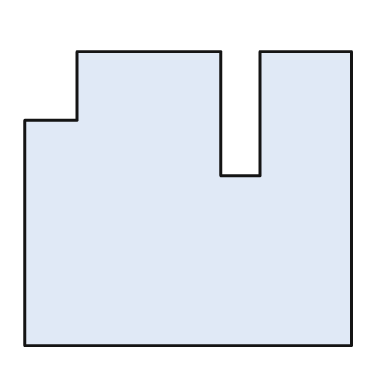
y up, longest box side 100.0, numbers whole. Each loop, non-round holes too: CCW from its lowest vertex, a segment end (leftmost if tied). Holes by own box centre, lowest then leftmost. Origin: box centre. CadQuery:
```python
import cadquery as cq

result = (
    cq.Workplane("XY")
    .moveTo(-50.0, -45.0)
    .lineTo(50.0, -45.0)
    .lineTo(50.0, 45.0)
    .lineTo(22.0, 45.0)
    .lineTo(22.0, 7.0)
    .lineTo(10.0, 7.0)
    .lineTo(10.0, 45.0)
    .lineTo(-34.0, 45.0)
    .lineTo(-34.0, 24.0)
    .lineTo(-50.0, 24.0)
    .close()
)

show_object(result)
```